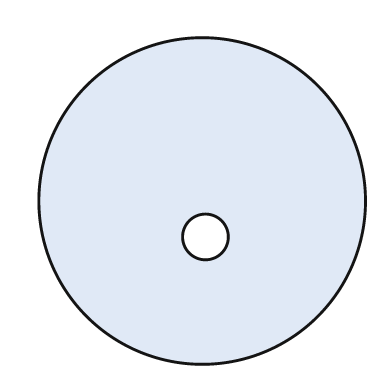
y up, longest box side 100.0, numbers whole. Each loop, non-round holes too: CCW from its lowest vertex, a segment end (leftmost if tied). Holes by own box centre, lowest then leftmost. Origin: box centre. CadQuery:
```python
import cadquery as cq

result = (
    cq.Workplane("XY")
    .moveTo(0.0, 0.0)
    .circle(50.0)
    .moveTo(1.0, -11.0)
    .circle(7.0)
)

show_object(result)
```